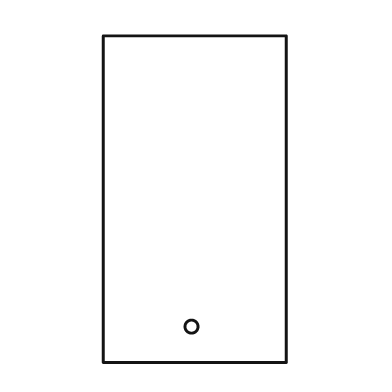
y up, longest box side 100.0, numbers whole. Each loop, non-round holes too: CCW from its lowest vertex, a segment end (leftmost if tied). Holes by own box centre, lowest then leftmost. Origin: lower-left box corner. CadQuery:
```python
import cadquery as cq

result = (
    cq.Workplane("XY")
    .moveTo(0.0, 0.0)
    .lineTo(56.0, 0.0)
    .lineTo(56.0, 100.0)
    .lineTo(0.0, 100.0)
    .close()
    .moveTo(27.0, 11.0)
    .circle(2.0)
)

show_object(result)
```